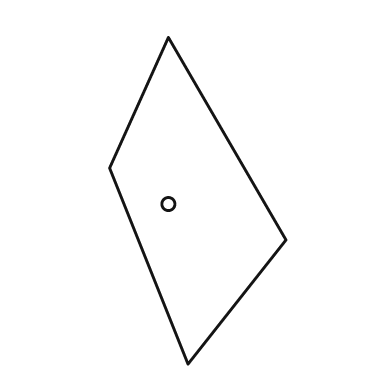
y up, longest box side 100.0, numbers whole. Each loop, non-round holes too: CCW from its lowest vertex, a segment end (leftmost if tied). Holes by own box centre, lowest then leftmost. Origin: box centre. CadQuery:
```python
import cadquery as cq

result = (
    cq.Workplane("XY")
    .moveTo(-3.0, -50.0)
    .lineTo(27.0, -12.0)
    .lineTo(-9.0, 50.0)
    .lineTo(-27.0, 10.0)
    .close()
    .moveTo(-9.0, -1.0)
    .circle(2.0)
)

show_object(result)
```